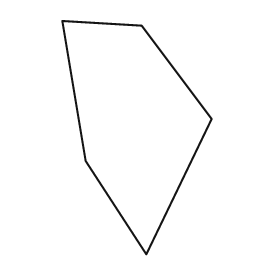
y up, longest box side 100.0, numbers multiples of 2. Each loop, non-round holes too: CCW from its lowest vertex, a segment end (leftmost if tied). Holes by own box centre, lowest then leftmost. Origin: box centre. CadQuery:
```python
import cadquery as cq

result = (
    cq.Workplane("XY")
    .moveTo(4.0, -50.0)
    .lineTo(32.0, 8.0)
    .lineTo(2.0, 48.0)
    .lineTo(-32.0, 50.0)
    .lineTo(-22.0, -10.0)
    .close()
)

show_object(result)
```